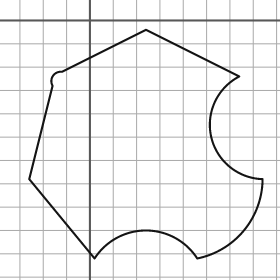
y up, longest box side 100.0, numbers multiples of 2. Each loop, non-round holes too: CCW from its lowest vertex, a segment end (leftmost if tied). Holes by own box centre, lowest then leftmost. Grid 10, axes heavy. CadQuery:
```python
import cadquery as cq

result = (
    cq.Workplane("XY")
    .moveTo(2.0, -102.0)
    .threePointArc((24.0, -90.0), (46.0, -102.0))
    .threePointArc((66.0, -90.0), (74.0, -68.0))
    .threePointArc((52.0, -50.0), (64.0, -24.0))
    .lineTo(24.0, -4.0)
    .lineTo(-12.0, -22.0)
    .threePointArc((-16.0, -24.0), (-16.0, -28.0))
    .lineTo(-26.0, -68.0)
    .close()
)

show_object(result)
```